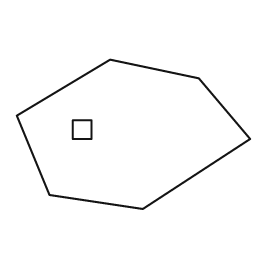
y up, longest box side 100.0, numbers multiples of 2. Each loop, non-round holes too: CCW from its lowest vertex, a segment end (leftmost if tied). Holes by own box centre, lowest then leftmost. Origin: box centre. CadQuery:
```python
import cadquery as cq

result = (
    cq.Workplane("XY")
    .moveTo(4.0, -32.0)
    .lineTo(50.0, -2.0)
    .lineTo(28.0, 24.0)
    .lineTo(-10.0, 32.0)
    .lineTo(-50.0, 8.0)
    .lineTo(-36.0, -26.0)
    .close()
    .moveTo(-26.0, -2.0)
    .lineTo(-18.0, -2.0)
    .lineTo(-18.0, 6.0)
    .lineTo(-26.0, 6.0)
    .close()
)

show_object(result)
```